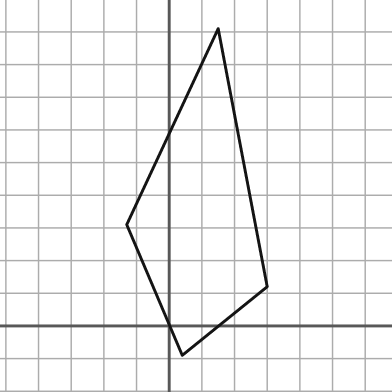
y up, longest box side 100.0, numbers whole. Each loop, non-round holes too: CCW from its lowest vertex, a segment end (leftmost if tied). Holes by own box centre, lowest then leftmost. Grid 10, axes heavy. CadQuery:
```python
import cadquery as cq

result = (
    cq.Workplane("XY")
    .moveTo(4.0, -9.0)
    .lineTo(30.0, 12.0)
    .lineTo(15.0, 91.0)
    .lineTo(-13.0, 31.0)
    .close()
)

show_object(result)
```